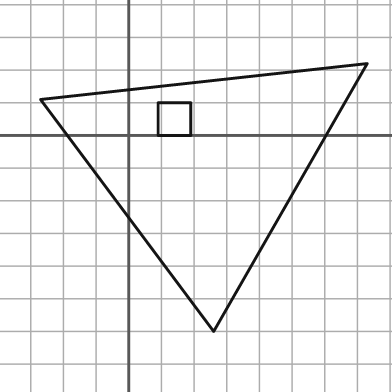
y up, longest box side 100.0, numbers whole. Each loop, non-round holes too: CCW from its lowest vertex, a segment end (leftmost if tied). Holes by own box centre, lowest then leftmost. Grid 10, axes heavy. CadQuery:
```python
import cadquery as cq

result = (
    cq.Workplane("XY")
    .moveTo(26.0, -60.0)
    .lineTo(73.0, 22.0)
    .lineTo(-27.0, 11.0)
    .close()
    .moveTo(9.0, 0.0)
    .lineTo(19.0, 0.0)
    .lineTo(19.0, 10.0)
    .lineTo(9.0, 10.0)
    .close()
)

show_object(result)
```